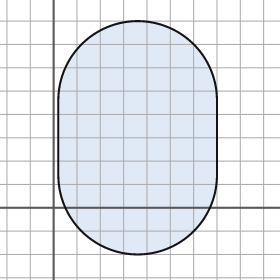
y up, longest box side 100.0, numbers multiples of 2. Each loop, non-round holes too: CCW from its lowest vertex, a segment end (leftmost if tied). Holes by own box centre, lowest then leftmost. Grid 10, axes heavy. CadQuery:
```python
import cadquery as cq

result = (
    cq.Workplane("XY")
    .moveTo(2.0, 14.0)
    .threePointArc((36.0, -20.0), (70.0, 14.0))
    .lineTo(70.0, 46.0)
    .threePointArc((36.0, 80.0), (2.0, 46.0))
    .close()
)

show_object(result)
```